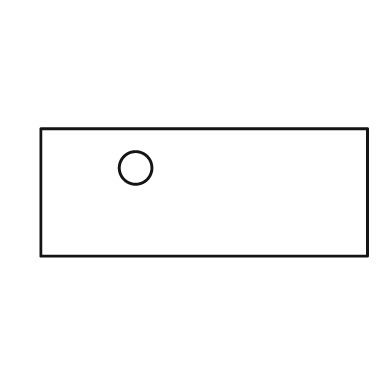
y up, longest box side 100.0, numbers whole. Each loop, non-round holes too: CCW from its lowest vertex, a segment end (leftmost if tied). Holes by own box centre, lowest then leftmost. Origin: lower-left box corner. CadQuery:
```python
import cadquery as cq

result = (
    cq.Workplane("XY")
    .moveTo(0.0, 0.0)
    .lineTo(100.0, 0.0)
    .lineTo(100.0, 39.0)
    .lineTo(0.0, 39.0)
    .close()
    .moveTo(29.0, 27.0)
    .circle(5.0)
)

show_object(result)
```